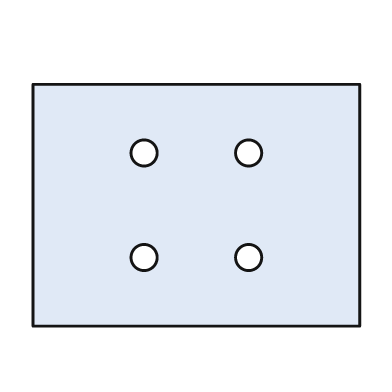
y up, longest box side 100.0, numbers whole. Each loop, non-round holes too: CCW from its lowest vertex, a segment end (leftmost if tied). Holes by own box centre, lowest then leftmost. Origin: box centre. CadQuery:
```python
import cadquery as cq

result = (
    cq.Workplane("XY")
    .moveTo(-50.0, -37.0)
    .lineTo(50.0, -37.0)
    .lineTo(50.0, 37.0)
    .lineTo(-50.0, 37.0)
    .close()
    .moveTo(-16.0, -16.0)
    .circle(4.0)
    .moveTo(16.0, -16.0)
    .circle(4.0)
    .moveTo(-16.0, 16.0)
    .circle(4.0)
    .moveTo(16.0, 16.0)
    .circle(4.0)
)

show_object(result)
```